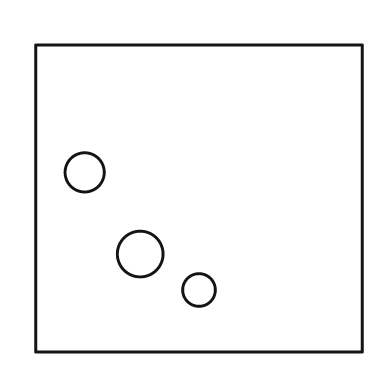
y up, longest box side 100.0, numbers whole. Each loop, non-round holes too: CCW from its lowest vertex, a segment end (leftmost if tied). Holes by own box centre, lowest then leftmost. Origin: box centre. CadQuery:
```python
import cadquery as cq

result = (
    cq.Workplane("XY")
    .moveTo(-50.0, -47.0)
    .lineTo(50.0, -47.0)
    .lineTo(50.0, 47.0)
    .lineTo(-50.0, 47.0)
    .close()
    .moveTo(0.0, -28.0)
    .circle(5.0)
    .moveTo(-18.0, -17.0)
    .circle(7.0)
    .moveTo(-35.0, 8.0)
    .circle(6.0)
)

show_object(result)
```